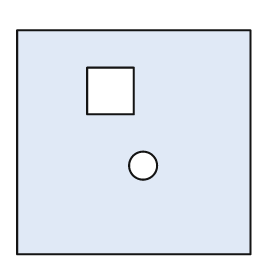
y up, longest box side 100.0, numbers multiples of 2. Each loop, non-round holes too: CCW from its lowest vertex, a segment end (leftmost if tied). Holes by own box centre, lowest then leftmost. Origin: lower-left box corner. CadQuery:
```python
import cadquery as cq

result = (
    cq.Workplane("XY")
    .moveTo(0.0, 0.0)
    .lineTo(100.0, 0.0)
    .lineTo(100.0, 96.0)
    .lineTo(0.0, 96.0)
    .close()
    .moveTo(54.0, 38.0)
    .circle(6.0)
    .moveTo(30.0, 60.0)
    .lineTo(50.0, 60.0)
    .lineTo(50.0, 80.0)
    .lineTo(30.0, 80.0)
    .close()
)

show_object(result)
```